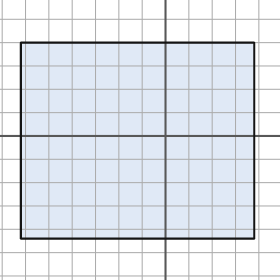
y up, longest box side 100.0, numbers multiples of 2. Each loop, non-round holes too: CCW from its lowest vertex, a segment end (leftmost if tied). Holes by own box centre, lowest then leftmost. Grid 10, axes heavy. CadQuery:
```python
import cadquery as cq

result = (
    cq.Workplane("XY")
    .moveTo(-62.0, -44.0)
    .lineTo(38.0, -44.0)
    .lineTo(38.0, 40.0)
    .lineTo(-62.0, 40.0)
    .close()
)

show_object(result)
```